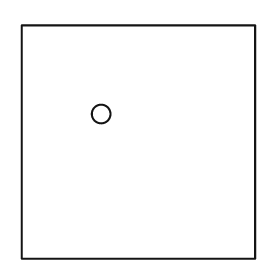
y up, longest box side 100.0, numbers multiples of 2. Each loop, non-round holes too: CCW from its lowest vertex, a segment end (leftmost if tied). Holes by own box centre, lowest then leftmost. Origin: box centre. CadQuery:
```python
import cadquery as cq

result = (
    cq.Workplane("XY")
    .moveTo(-50.0, -50.0)
    .lineTo(50.0, -50.0)
    .lineTo(50.0, 50.0)
    .lineTo(-50.0, 50.0)
    .close()
    .moveTo(-16.0, 12.0)
    .circle(4.0)
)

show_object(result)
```